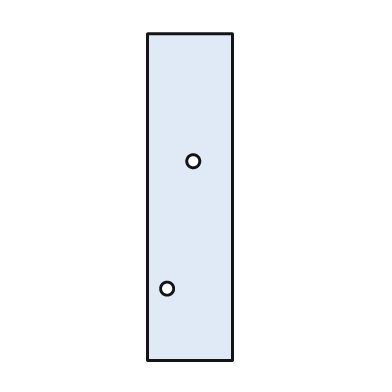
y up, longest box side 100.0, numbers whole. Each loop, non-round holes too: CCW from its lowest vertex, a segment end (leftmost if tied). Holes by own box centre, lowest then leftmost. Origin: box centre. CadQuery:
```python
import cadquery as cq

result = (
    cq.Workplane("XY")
    .moveTo(-13.0, -50.0)
    .lineTo(13.0, -50.0)
    .lineTo(13.0, 50.0)
    .lineTo(-13.0, 50.0)
    .close()
    .moveTo(-7.0, -28.0)
    .circle(2.0)
    .moveTo(1.0, 11.0)
    .circle(2.0)
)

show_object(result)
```